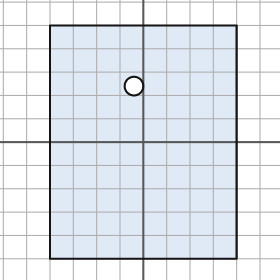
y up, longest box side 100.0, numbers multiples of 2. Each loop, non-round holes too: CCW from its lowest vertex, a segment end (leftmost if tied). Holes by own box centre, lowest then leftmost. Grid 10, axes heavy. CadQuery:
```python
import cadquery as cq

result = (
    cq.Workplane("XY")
    .moveTo(-40.0, -50.0)
    .lineTo(40.0, -50.0)
    .lineTo(40.0, 50.0)
    .lineTo(-40.0, 50.0)
    .close()
    .moveTo(-4.0, 24.0)
    .circle(4.0)
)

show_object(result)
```